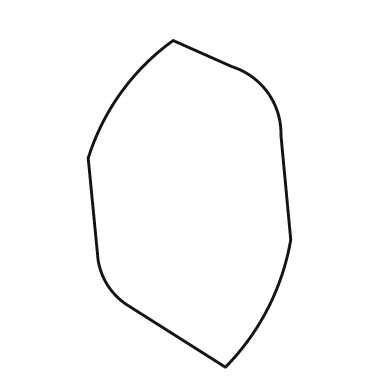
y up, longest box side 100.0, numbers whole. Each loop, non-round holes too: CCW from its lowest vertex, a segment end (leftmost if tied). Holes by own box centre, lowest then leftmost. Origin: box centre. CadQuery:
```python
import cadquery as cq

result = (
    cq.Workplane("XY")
    .moveTo(11.0, -50.0)
    .threePointArc((24.0, -32.0), (31.0, -11.0))
    .lineTo(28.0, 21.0)
    .threePointArc((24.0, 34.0), (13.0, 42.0))
    .lineTo(-5.0, 50.0)
    .threePointArc((-21.0, 34.0), (-31.0, 14.0))
    .lineTo(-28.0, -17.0)
    .threePointArc((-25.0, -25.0), (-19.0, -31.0))
    .close()
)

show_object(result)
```